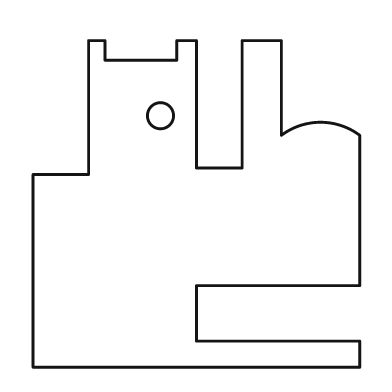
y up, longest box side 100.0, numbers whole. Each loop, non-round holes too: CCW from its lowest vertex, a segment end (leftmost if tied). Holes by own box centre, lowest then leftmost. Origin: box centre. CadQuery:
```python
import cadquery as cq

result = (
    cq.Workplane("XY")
    .moveTo(-50.0, -50.0)
    .lineTo(50.0, -50.0)
    .lineTo(50.0, -42.0)
    .lineTo(0.0, -42.0)
    .lineTo(0.0, -25.0)
    .lineTo(50.0, -25.0)
    .lineTo(50.0, 21.0)
    .threePointArc((38.0, 25.0), (26.0, 21.0))
    .lineTo(26.0, 50.0)
    .lineTo(14.0, 50.0)
    .lineTo(14.0, 11.0)
    .lineTo(0.0, 11.0)
    .lineTo(0.0, 50.0)
    .lineTo(-6.0, 50.0)
    .lineTo(-6.0, 44.0)
    .lineTo(-28.0, 44.0)
    .lineTo(-28.0, 50.0)
    .lineTo(-33.0, 50.0)
    .lineTo(-33.0, 9.0)
    .lineTo(-50.0, 9.0)
    .close()
    .moveTo(-11.0, 27.0)
    .circle(4.0)
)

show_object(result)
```